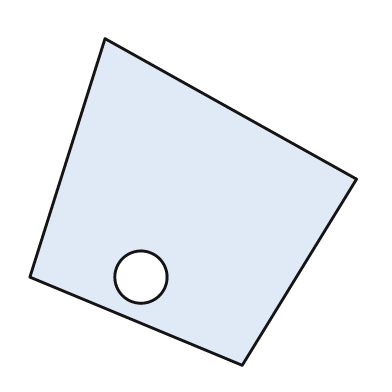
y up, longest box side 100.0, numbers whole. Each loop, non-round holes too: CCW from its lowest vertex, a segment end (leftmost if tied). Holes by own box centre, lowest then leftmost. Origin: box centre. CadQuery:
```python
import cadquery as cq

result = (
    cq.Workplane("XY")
    .moveTo(15.0, -50.0)
    .lineTo(50.0, 7.0)
    .lineTo(-27.0, 50.0)
    .lineTo(-50.0, -23.0)
    .close()
    .moveTo(-16.0, -23.0)
    .circle(8.0)
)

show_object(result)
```